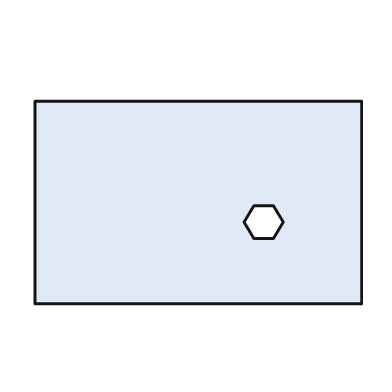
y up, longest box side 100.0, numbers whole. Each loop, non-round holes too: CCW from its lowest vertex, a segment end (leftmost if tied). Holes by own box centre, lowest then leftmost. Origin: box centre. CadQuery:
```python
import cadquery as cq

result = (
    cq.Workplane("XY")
    .moveTo(-50.0, -31.0)
    .lineTo(50.0, -31.0)
    .lineTo(50.0, 31.0)
    .lineTo(-50.0, 31.0)
    .close()
    .moveTo(17.0, -11.0)
    .lineTo(23.0, -11.0)
    .lineTo(26.0, -6.0)
    .lineTo(23.0, -1.0)
    .lineTo(17.0, -1.0)
    .lineTo(14.0, -6.0)
    .close()
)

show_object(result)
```